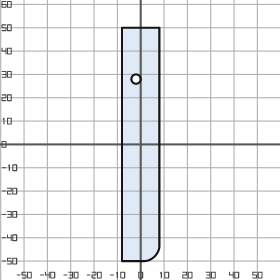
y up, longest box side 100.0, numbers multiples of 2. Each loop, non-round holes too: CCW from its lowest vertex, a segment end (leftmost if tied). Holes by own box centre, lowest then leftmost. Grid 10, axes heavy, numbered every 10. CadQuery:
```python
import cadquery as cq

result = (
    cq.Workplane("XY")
    .moveTo(-8.0, -50.0)
    .lineTo(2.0, -50.0)
    .threePointArc((6.0, -48.0), (8.0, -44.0))
    .lineTo(8.0, 50.0)
    .lineTo(-8.0, 50.0)
    .close()
    .moveTo(-2.0, 28.0)
    .circle(2.0)
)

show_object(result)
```